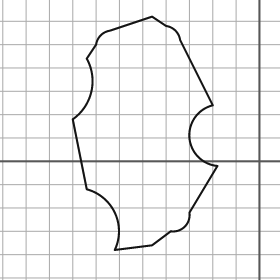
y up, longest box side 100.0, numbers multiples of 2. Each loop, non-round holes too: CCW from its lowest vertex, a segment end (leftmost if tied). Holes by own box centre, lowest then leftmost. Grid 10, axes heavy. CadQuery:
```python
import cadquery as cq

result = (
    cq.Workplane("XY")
    .moveTo(-62.0, -38.0)
    .lineTo(-46.0, -36.0)
    .lineTo(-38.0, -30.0)
    .threePointArc((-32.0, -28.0), (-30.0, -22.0))
    .lineTo(-18.0, -2.0)
    .threePointArc((-30.0, 10.0), (-20.0, 24.0))
    .lineTo(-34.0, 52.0)
    .threePointArc((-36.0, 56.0), (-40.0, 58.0))
    .lineTo(-46.0, 62.0)
    .lineTo(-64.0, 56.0)
    .threePointArc((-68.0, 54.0), (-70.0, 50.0))
    .lineTo(-74.0, 44.0)
    .threePointArc((-72.0, 30.0), (-80.0, 18.0))
    .lineTo(-74.0, -12.0)
    .threePointArc((-62.0, -22.0), (-62.0, -38.0))
    .close()
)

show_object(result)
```